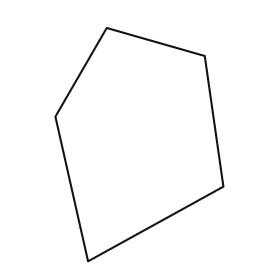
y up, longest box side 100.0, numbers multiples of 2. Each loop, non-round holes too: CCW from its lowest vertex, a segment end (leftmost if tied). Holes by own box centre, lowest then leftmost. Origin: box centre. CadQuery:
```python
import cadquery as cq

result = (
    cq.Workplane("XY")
    .moveTo(-22.0, -50.0)
    .lineTo(36.0, -18.0)
    .lineTo(28.0, 38.0)
    .lineTo(-14.0, 50.0)
    .lineTo(-36.0, 12.0)
    .close()
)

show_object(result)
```